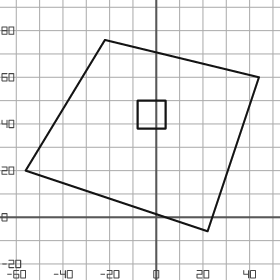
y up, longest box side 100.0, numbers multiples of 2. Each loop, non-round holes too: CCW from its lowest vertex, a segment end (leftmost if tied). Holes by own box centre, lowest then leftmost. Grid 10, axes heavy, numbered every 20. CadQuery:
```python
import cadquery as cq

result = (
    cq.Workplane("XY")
    .moveTo(22.0, -6.0)
    .lineTo(44.0, 60.0)
    .lineTo(-22.0, 76.0)
    .lineTo(-56.0, 20.0)
    .close()
    .moveTo(-8.0, 38.0)
    .lineTo(4.0, 38.0)
    .lineTo(4.0, 50.0)
    .lineTo(-8.0, 50.0)
    .close()
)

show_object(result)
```